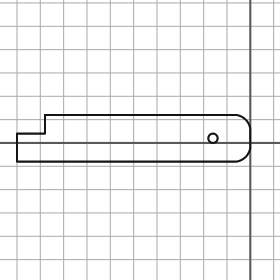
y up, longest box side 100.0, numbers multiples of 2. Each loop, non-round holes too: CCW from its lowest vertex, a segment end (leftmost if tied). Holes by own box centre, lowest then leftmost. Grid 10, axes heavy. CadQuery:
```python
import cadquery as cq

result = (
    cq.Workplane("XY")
    .moveTo(-100.0, -8.0)
    .lineTo(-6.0, -8.0)
    .threePointArc((-2.0, -6.0), (0.0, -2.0))
    .lineTo(0.0, 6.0)
    .threePointArc((-2.0, 10.0), (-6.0, 12.0))
    .lineTo(-88.0, 12.0)
    .lineTo(-88.0, 4.0)
    .lineTo(-100.0, 4.0)
    .close()
    .moveTo(-16.0, 2.0)
    .circle(2.0)
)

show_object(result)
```